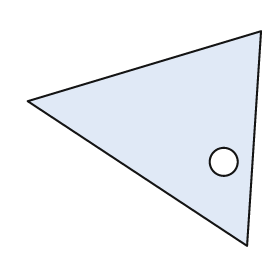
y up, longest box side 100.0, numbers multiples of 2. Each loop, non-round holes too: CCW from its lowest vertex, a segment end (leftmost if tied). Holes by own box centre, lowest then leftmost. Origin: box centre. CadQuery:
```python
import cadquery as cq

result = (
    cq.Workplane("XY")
    .moveTo(44.0, -46.0)
    .lineTo(50.0, 46.0)
    .lineTo(-50.0, 16.0)
    .close()
    .moveTo(34.0, -10.0)
    .circle(6.0)
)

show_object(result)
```